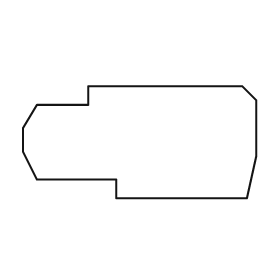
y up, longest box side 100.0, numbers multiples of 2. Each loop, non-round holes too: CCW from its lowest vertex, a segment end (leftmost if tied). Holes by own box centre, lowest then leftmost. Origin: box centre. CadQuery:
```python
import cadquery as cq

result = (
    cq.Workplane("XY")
    .moveTo(-10.0, -24.0)
    .lineTo(46.0, -24.0)
    .lineTo(50.0, -6.0)
    .lineTo(50.0, 18.0)
    .lineTo(44.0, 24.0)
    .lineTo(-22.0, 24.0)
    .lineTo(-22.0, 16.0)
    .lineTo(-44.0, 16.0)
    .lineTo(-50.0, 6.0)
    .lineTo(-50.0, -4.0)
    .lineTo(-44.0, -16.0)
    .lineTo(-10.0, -16.0)
    .close()
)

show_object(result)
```